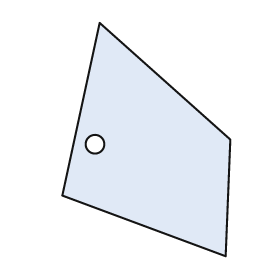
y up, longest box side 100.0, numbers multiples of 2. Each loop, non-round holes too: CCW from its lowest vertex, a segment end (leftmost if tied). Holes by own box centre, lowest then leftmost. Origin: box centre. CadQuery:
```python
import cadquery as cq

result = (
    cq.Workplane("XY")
    .moveTo(34.0, -50.0)
    .lineTo(36.0, 0.0)
    .lineTo(-20.0, 50.0)
    .lineTo(-36.0, -24.0)
    .close()
    .moveTo(-22.0, -2.0)
    .circle(4.0)
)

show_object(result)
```